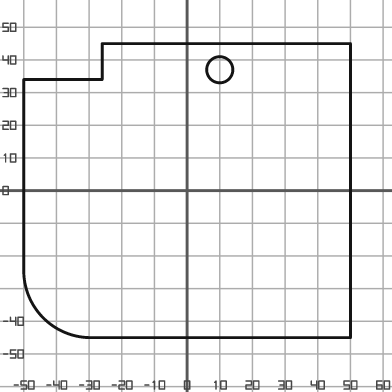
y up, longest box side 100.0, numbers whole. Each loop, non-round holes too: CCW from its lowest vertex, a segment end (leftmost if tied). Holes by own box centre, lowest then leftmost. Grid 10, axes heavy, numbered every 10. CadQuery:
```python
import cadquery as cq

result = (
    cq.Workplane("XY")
    .moveTo(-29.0, -45.0)
    .lineTo(50.0, -45.0)
    .lineTo(50.0, 45.0)
    .lineTo(-26.0, 45.0)
    .lineTo(-26.0, 34.0)
    .lineTo(-50.0, 34.0)
    .lineTo(-50.0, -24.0)
    .threePointArc((-44.0, -39.0), (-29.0, -45.0))
    .close()
    .moveTo(10.0, 37.0)
    .circle(4.0)
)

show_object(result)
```